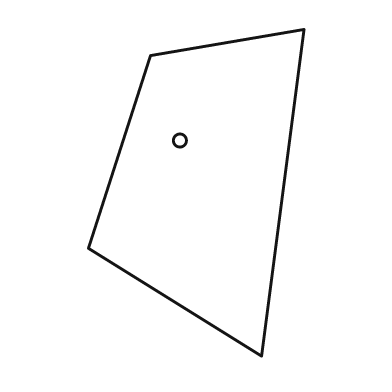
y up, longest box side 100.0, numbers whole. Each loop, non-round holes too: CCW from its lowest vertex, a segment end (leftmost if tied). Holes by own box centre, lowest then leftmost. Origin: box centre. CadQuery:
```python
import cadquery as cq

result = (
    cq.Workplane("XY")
    .moveTo(20.0, -50.0)
    .lineTo(33.0, 50.0)
    .lineTo(-14.0, 42.0)
    .lineTo(-33.0, -17.0)
    .close()
    .moveTo(-5.0, 16.0)
    .circle(2.0)
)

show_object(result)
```